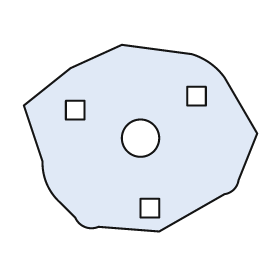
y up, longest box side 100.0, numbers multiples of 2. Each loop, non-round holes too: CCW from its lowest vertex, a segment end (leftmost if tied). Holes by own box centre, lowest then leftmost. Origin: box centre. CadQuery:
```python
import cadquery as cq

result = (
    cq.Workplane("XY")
    .moveTo(8.0, -40.0)
    .lineTo(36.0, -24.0)
    .threePointArc((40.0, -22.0), (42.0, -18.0))
    .lineTo(50.0, 2.0)
    .lineTo(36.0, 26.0)
    .threePointArc((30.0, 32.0), (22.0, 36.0))
    .lineTo(-8.0, 40.0)
    .lineTo(-30.0, 30.0)
    .lineTo(-50.0, 14.0)
    .lineTo(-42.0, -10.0)
    .threePointArc((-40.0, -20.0), (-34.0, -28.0))
    .lineTo(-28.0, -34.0)
    .threePointArc((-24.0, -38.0), (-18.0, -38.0))
    .close()
    .moveTo(0.0, -34.0)
    .lineTo(8.0, -34.0)
    .lineTo(8.0, -26.0)
    .lineTo(0.0, -26.0)
    .close()
    .moveTo(0.0, 0.0)
    .circle(8.0)
    .moveTo(-32.0, 8.0)
    .lineTo(-24.0, 8.0)
    .lineTo(-24.0, 16.0)
    .lineTo(-32.0, 16.0)
    .close()
    .moveTo(20.0, 14.0)
    .lineTo(28.0, 14.0)
    .lineTo(28.0, 22.0)
    .lineTo(20.0, 22.0)
    .close()
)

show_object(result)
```